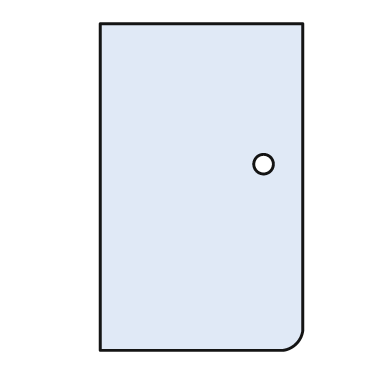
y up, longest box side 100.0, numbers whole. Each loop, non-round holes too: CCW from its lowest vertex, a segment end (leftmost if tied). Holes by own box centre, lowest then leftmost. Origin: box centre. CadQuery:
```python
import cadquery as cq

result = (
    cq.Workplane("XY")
    .moveTo(-31.0, -50.0)
    .lineTo(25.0, -50.0)
    .threePointArc((29.0, -48.0), (31.0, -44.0))
    .lineTo(31.0, 50.0)
    .lineTo(-31.0, 50.0)
    .close()
    .moveTo(19.0, 7.0)
    .circle(3.0)
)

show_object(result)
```